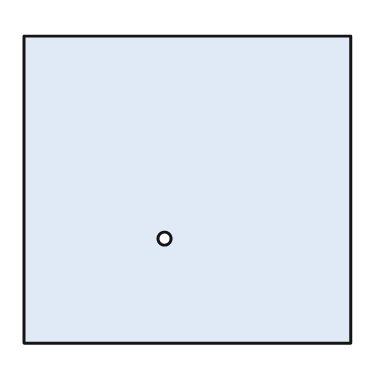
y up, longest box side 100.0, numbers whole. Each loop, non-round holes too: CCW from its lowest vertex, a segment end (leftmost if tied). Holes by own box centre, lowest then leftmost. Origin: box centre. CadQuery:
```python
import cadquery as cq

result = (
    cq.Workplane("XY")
    .moveTo(-50.0, -47.0)
    .lineTo(50.0, -47.0)
    .lineTo(50.0, 47.0)
    .lineTo(-50.0, 47.0)
    .close()
    .moveTo(-7.0, -15.0)
    .circle(2.0)
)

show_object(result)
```